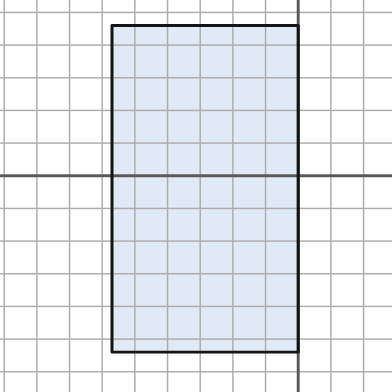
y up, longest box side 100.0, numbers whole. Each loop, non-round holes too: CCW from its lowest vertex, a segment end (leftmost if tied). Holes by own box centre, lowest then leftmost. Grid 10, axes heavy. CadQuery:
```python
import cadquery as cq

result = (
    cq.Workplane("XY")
    .moveTo(-57.0, -54.0)
    .lineTo(0.0, -54.0)
    .lineTo(0.0, 46.0)
    .lineTo(-57.0, 46.0)
    .close()
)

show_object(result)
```